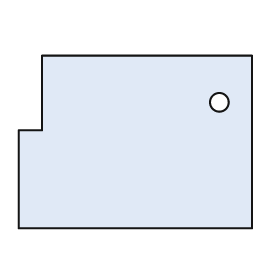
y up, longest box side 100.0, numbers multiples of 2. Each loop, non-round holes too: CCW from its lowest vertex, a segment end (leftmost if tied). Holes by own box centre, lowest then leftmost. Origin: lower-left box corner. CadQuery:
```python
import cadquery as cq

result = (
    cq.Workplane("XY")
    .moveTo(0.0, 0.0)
    .lineTo(100.0, 0.0)
    .lineTo(100.0, 74.0)
    .lineTo(10.0, 74.0)
    .lineTo(10.0, 42.0)
    .lineTo(0.0, 42.0)
    .close()
    .moveTo(86.0, 54.0)
    .circle(4.0)
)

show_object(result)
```